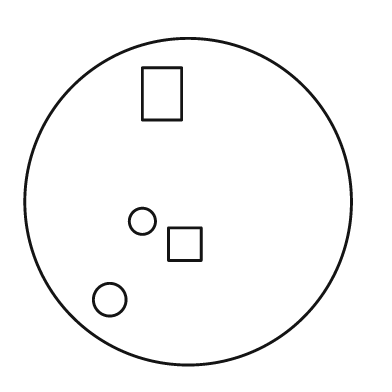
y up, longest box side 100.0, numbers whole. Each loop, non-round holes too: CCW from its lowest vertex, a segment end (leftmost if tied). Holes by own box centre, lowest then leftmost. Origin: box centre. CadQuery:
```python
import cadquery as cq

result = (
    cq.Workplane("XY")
    .moveTo(0.0, 0.0)
    .circle(50.0)
    .moveTo(-24.0, -30.0)
    .circle(5.0)
    .moveTo(-6.0, -18.0)
    .lineTo(4.0, -18.0)
    .lineTo(4.0, -8.0)
    .lineTo(-6.0, -8.0)
    .close()
    .moveTo(-14.0, -6.0)
    .circle(4.0)
    .moveTo(-14.0, 25.0)
    .lineTo(-2.0, 25.0)
    .lineTo(-2.0, 41.0)
    .lineTo(-14.0, 41.0)
    .close()
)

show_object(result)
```